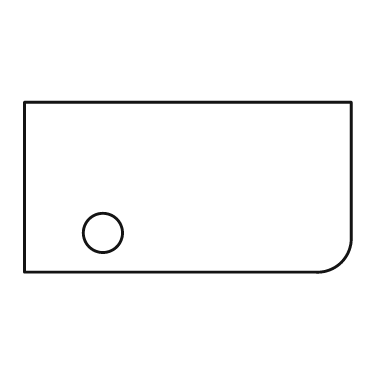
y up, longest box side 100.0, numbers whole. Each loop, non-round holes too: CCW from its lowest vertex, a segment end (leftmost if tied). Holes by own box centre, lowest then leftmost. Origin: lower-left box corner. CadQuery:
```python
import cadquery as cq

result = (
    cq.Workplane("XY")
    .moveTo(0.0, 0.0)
    .lineTo(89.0, 0.0)
    .threePointArc((97.0, 3.0), (100.0, 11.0))
    .lineTo(100.0, 52.0)
    .lineTo(0.0, 52.0)
    .close()
    .moveTo(24.0, 12.0)
    .circle(6.0)
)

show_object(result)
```